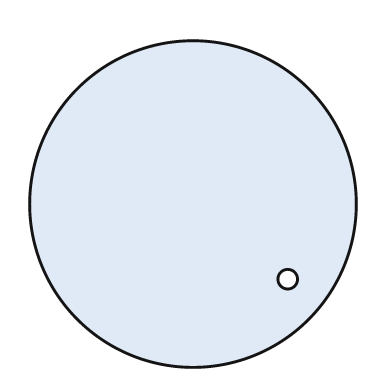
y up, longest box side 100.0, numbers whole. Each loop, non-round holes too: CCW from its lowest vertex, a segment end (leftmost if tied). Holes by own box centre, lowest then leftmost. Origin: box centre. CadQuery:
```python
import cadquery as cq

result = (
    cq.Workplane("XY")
    .moveTo(0.0, 0.0)
    .circle(50.0)
    .moveTo(29.0, -23.0)
    .circle(3.0)
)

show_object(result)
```